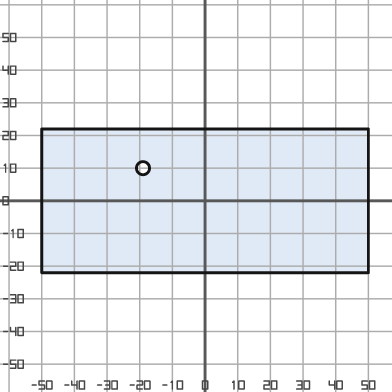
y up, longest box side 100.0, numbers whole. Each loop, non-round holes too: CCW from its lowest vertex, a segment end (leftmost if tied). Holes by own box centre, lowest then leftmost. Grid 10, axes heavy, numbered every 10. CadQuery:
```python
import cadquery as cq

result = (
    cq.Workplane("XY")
    .moveTo(-50.0, -22.0)
    .lineTo(50.0, -22.0)
    .lineTo(50.0, 22.0)
    .lineTo(-50.0, 22.0)
    .close()
    .moveTo(-19.0, 10.0)
    .circle(2.0)
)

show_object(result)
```